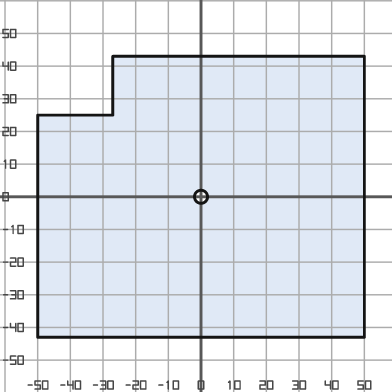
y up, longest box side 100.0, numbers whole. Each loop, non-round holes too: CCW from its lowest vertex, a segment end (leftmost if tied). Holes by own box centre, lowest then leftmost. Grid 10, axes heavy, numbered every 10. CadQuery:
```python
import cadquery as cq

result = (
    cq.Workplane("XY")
    .moveTo(-50.0, -43.0)
    .lineTo(50.0, -43.0)
    .lineTo(50.0, 43.0)
    .lineTo(-27.0, 43.0)
    .lineTo(-27.0, 25.0)
    .lineTo(-50.0, 25.0)
    .close()
    .moveTo(0.0, 0.0)
    .circle(2.0)
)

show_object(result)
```